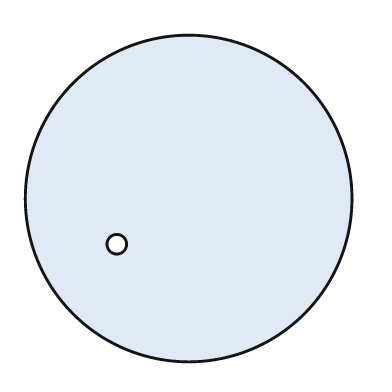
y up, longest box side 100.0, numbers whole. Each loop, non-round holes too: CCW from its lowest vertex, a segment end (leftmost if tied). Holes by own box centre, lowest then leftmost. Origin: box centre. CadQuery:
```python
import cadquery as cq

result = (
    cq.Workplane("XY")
    .moveTo(0.0, 0.0)
    .circle(50.0)
    .moveTo(-22.0, -14.0)
    .circle(3.0)
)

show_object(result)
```